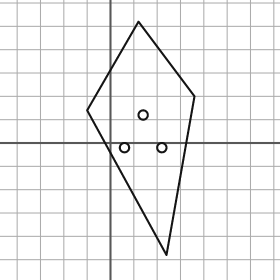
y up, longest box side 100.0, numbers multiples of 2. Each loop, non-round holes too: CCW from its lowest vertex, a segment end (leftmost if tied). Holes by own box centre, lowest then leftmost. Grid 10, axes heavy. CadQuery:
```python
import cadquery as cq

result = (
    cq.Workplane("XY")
    .moveTo(24.0, -48.0)
    .lineTo(36.0, 20.0)
    .lineTo(12.0, 52.0)
    .lineTo(-10.0, 14.0)
    .close()
    .moveTo(6.0, -2.0)
    .circle(2.0)
    .moveTo(22.0, -2.0)
    .circle(2.0)
    .moveTo(14.0, 12.0)
    .circle(2.0)
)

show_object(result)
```